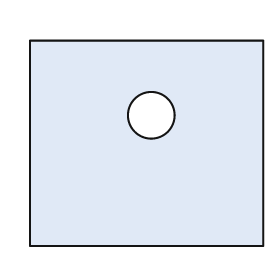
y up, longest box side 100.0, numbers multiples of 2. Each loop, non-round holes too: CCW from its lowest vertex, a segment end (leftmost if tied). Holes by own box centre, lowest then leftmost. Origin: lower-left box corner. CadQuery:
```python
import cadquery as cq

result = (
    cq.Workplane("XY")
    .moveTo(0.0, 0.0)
    .lineTo(100.0, 0.0)
    .lineTo(100.0, 88.0)
    .lineTo(0.0, 88.0)
    .close()
    .moveTo(52.0, 56.0)
    .circle(10.0)
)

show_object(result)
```